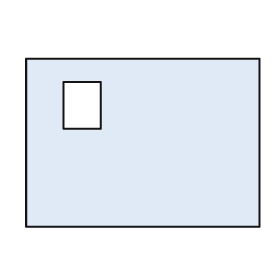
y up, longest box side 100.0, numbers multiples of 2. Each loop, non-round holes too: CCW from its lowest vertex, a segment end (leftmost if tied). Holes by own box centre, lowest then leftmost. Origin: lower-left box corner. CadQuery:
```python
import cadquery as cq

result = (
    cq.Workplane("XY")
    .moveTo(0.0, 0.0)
    .lineTo(100.0, 0.0)
    .lineTo(100.0, 72.0)
    .lineTo(0.0, 72.0)
    .close()
    .moveTo(16.0, 42.0)
    .lineTo(32.0, 42.0)
    .lineTo(32.0, 62.0)
    .lineTo(16.0, 62.0)
    .close()
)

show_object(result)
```